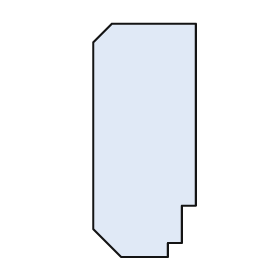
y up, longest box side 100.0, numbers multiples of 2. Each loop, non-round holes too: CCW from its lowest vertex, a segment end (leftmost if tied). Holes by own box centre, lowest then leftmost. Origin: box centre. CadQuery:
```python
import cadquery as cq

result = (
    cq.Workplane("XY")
    .moveTo(-10.0, -50.0)
    .lineTo(10.0, -50.0)
    .lineTo(10.0, -44.0)
    .lineTo(16.0, -44.0)
    .lineTo(16.0, -28.0)
    .lineTo(22.0, -28.0)
    .lineTo(22.0, 50.0)
    .lineTo(-14.0, 50.0)
    .lineTo(-22.0, 42.0)
    .lineTo(-22.0, -38.0)
    .close()
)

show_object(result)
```